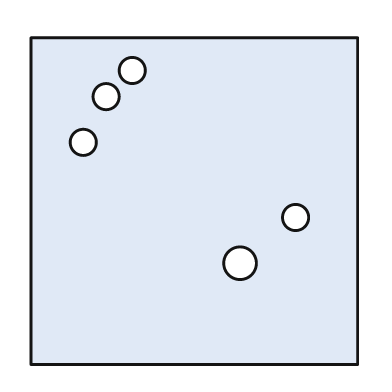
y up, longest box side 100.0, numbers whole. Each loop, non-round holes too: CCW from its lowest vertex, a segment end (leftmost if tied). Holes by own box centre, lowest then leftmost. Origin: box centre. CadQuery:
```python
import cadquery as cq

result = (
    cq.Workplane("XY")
    .moveTo(-50.0, -50.0)
    .lineTo(50.0, -50.0)
    .lineTo(50.0, 50.0)
    .lineTo(-50.0, 50.0)
    .close()
    .moveTo(14.0, -19.0)
    .circle(5.0)
    .moveTo(31.0, -5.0)
    .circle(4.0)
    .moveTo(-34.0, 18.0)
    .circle(4.0)
    .moveTo(-27.0, 32.0)
    .circle(4.0)
    .moveTo(-19.0, 40.0)
    .circle(4.0)
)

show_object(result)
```